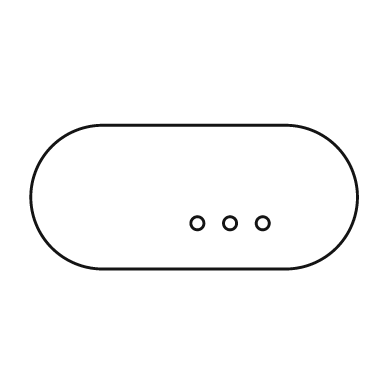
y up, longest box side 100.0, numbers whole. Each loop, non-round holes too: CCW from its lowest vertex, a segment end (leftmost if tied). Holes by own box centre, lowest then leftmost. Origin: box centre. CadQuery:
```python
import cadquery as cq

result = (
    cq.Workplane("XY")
    .moveTo(-28.0, -22.0)
    .lineTo(28.0, -22.0)
    .threePointArc((50.0, 0.0), (28.0, 22.0))
    .lineTo(-28.0, 22.0)
    .threePointArc((-50.0, 0.0), (-28.0, -22.0))
    .close()
    .moveTo(1.0, -8.0)
    .circle(2.0)
    .moveTo(11.0, -8.0)
    .circle(2.0)
    .moveTo(21.0, -8.0)
    .circle(2.0)
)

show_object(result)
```